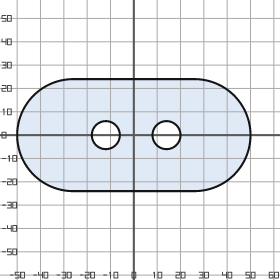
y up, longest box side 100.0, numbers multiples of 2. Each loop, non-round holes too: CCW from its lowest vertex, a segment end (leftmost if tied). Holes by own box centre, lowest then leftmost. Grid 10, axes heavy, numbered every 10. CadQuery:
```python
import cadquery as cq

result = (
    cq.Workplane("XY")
    .moveTo(-26.0, -24.0)
    .lineTo(26.0, -24.0)
    .threePointArc((50.0, 0.0), (26.0, 24.0))
    .lineTo(-26.0, 24.0)
    .threePointArc((-50.0, 0.0), (-26.0, -24.0))
    .close()
    .moveTo(-12.0, 0.0)
    .circle(6.0)
    .moveTo(14.0, 0.0)
    .circle(6.0)
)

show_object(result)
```